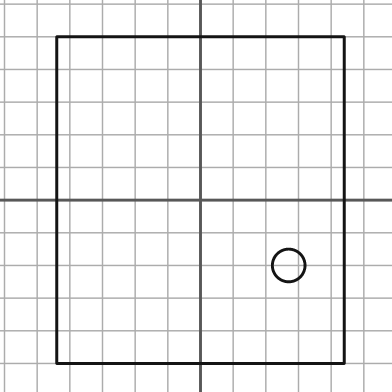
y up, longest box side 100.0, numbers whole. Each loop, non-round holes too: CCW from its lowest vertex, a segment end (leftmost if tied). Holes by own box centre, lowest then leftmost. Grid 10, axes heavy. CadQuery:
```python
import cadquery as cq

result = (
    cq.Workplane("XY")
    .moveTo(-44.0, -50.0)
    .lineTo(44.0, -50.0)
    .lineTo(44.0, 50.0)
    .lineTo(-44.0, 50.0)
    .close()
    .moveTo(27.0, -20.0)
    .circle(5.0)
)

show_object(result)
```